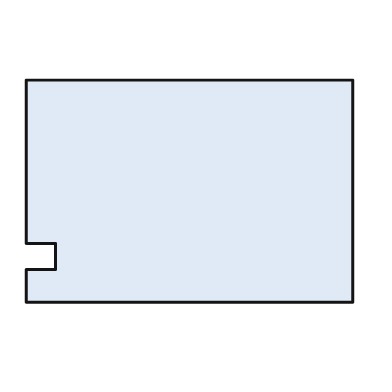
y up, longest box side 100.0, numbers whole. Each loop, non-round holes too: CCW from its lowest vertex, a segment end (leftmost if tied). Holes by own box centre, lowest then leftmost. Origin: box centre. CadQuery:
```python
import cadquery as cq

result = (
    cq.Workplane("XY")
    .moveTo(-50.0, -34.0)
    .lineTo(50.0, -34.0)
    .lineTo(50.0, 34.0)
    .lineTo(-50.0, 34.0)
    .lineTo(-50.0, -16.0)
    .lineTo(-41.0, -16.0)
    .lineTo(-41.0, -24.0)
    .lineTo(-50.0, -24.0)
    .close()
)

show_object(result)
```